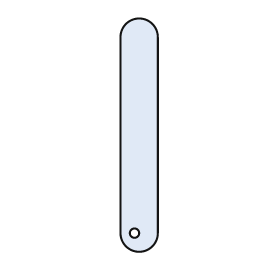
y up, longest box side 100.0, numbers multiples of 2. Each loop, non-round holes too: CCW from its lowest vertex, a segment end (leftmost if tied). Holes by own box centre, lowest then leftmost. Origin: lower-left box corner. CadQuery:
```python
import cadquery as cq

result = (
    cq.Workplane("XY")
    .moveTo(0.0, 8.0)
    .threePointArc((8.0, 0.0), (16.0, 8.0))
    .lineTo(16.0, 92.0)
    .threePointArc((8.0, 100.0), (0.0, 92.0))
    .close()
    .moveTo(6.0, 8.0)
    .circle(2.0)
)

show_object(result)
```